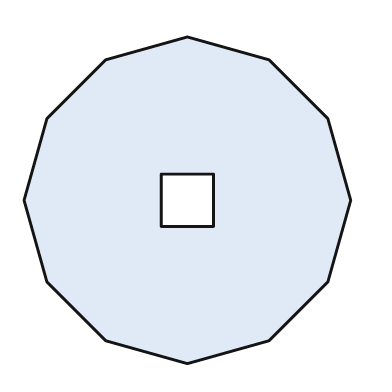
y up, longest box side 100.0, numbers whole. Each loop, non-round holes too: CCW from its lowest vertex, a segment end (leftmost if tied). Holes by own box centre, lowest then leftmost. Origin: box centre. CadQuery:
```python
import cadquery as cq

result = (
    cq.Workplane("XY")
    .moveTo(0.0, -50.0)
    .lineTo(25.0, -43.0)
    .lineTo(43.0, -25.0)
    .lineTo(50.0, 0.0)
    .lineTo(43.0, 25.0)
    .lineTo(25.0, 43.0)
    .lineTo(0.0, 50.0)
    .lineTo(-25.0, 43.0)
    .lineTo(-43.0, 25.0)
    .lineTo(-50.0, 0.0)
    .lineTo(-43.0, -25.0)
    .lineTo(-25.0, -43.0)
    .close()
    .moveTo(-8.0, -8.0)
    .lineTo(8.0, -8.0)
    .lineTo(8.0, 8.0)
    .lineTo(-8.0, 8.0)
    .close()
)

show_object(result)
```